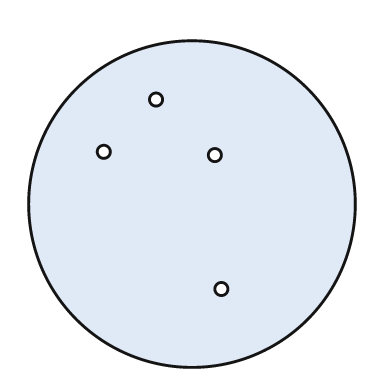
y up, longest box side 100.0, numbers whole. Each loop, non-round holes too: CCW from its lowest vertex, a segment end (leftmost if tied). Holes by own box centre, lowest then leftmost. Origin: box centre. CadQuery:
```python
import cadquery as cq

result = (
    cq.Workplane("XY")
    .moveTo(0.0, 0.0)
    .circle(50.0)
    .moveTo(9.0, -26.0)
    .circle(2.0)
    .moveTo(7.0, 15.0)
    .circle(2.0)
    .moveTo(-27.0, 16.0)
    .circle(2.0)
    .moveTo(-11.0, 32.0)
    .circle(2.0)
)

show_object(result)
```